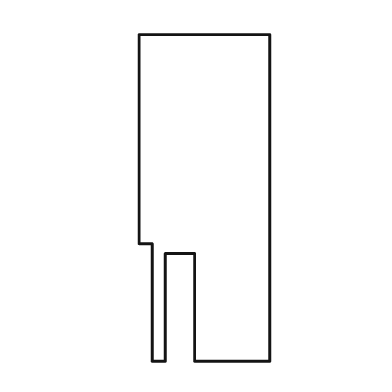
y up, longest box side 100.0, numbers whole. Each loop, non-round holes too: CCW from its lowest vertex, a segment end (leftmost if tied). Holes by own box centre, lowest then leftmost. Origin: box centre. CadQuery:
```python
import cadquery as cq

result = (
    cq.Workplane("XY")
    .moveTo(-16.0, -50.0)
    .lineTo(-12.0, -50.0)
    .lineTo(-12.0, -17.0)
    .lineTo(-3.0, -17.0)
    .lineTo(-3.0, -50.0)
    .lineTo(20.0, -50.0)
    .lineTo(20.0, 50.0)
    .lineTo(-20.0, 50.0)
    .lineTo(-20.0, -14.0)
    .lineTo(-16.0, -14.0)
    .close()
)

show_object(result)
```